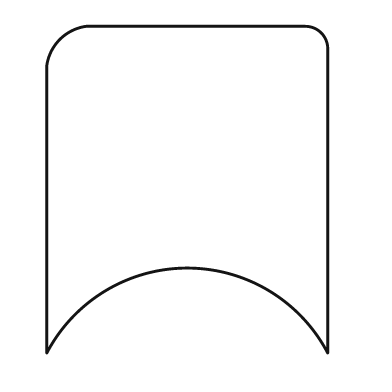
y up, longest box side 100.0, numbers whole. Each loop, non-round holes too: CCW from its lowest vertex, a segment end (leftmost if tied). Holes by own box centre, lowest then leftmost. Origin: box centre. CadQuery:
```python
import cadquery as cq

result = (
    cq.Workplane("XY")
    .moveTo(-43.0, -50.0)
    .threePointArc((0.0, -24.0), (43.0, -50.0))
    .lineTo(43.0, 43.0)
    .threePointArc((41.0, 48.0), (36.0, 50.0))
    .lineTo(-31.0, 50.0)
    .threePointArc((-39.0, 46.0), (-43.0, 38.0))
    .close()
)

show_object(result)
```